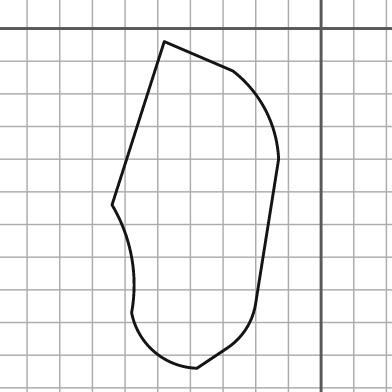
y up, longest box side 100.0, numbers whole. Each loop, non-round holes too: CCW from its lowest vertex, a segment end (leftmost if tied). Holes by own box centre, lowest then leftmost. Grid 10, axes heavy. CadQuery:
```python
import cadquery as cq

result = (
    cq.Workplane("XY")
    .moveTo(-38.0, -104.0)
    .lineTo(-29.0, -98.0)
    .threePointArc((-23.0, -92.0), (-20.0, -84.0))
    .lineTo(-13.0, -40.0)
    .threePointArc((-17.0, -25.0), (-27.0, -13.0))
    .lineTo(-48.0, -4.0)
    .lineTo(-64.0, -54.0)
    .threePointArc((-58.0, -70.0), (-58.0, -87.0))
    .threePointArc((-51.0, -99.0), (-38.0, -104.0))
    .close()
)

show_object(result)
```